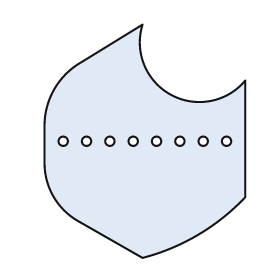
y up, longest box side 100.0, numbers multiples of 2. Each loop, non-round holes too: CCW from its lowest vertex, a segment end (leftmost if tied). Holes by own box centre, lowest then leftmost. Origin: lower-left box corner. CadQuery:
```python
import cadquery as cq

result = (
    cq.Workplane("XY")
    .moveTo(42.0, 0.0)
    .threePointArc((66.0, 10.0), (86.0, 26.0))
    .lineTo(86.0, 76.0)
    .threePointArc((54.0, 70.0), (42.0, 100.0))
    .lineTo(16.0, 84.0)
    .threePointArc((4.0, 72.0), (0.0, 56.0))
    .lineTo(0.0, 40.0)
    .threePointArc((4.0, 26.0), (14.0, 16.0))
    .close()
    .moveTo(8.0, 50.0)
    .circle(2.0)
    .moveTo(18.0, 50.0)
    .circle(2.0)
    .moveTo(28.0, 50.0)
    .circle(2.0)
    .moveTo(38.0, 50.0)
    .circle(2.0)
    .moveTo(48.0, 50.0)
    .circle(2.0)
    .moveTo(58.0, 50.0)
    .circle(2.0)
    .moveTo(68.0, 50.0)
    .circle(2.0)
    .moveTo(78.0, 50.0)
    .circle(2.0)
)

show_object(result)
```